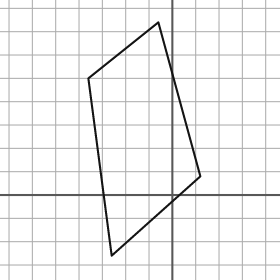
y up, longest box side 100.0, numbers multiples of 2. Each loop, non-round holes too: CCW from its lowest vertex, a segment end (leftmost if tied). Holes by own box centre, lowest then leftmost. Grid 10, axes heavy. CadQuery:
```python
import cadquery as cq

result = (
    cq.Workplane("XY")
    .moveTo(-26.0, -26.0)
    .lineTo(12.0, 8.0)
    .lineTo(-6.0, 74.0)
    .lineTo(-36.0, 50.0)
    .close()
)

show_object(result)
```